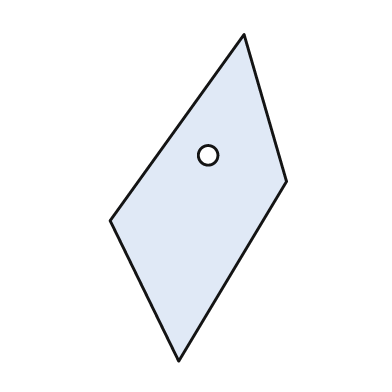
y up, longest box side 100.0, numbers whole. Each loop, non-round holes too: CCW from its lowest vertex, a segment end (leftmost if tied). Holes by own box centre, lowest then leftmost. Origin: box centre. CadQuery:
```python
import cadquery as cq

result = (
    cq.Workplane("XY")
    .moveTo(-6.0, -50.0)
    .lineTo(27.0, 5.0)
    .lineTo(14.0, 50.0)
    .lineTo(-27.0, -7.0)
    .close()
    .moveTo(3.0, 13.0)
    .circle(3.0)
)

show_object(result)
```